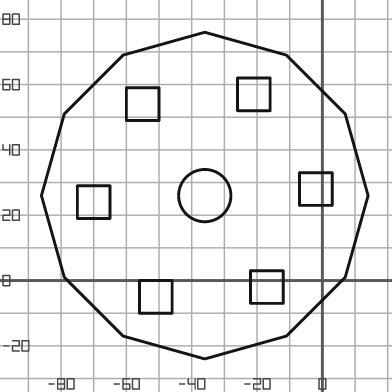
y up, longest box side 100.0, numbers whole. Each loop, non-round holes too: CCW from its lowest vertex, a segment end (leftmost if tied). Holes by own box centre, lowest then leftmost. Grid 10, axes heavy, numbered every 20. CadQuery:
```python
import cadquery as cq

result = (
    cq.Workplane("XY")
    .moveTo(-36.0, -24.0)
    .lineTo(-11.0, -17.0)
    .lineTo(7.0, 1.0)
    .lineTo(14.0, 26.0)
    .lineTo(7.0, 51.0)
    .lineTo(-11.0, 69.0)
    .lineTo(-36.0, 76.0)
    .lineTo(-61.0, 69.0)
    .lineTo(-79.0, 51.0)
    .lineTo(-86.0, 26.0)
    .lineTo(-79.0, 1.0)
    .lineTo(-61.0, -17.0)
    .close()
    .moveTo(-56.0, -10.0)
    .lineTo(-46.0, -10.0)
    .lineTo(-46.0, 0.0)
    .lineTo(-56.0, 0.0)
    .close()
    .moveTo(-22.0, -7.0)
    .lineTo(-12.0, -7.0)
    .lineTo(-12.0, 3.0)
    .lineTo(-22.0, 3.0)
    .close()
    .moveTo(-75.0, 19.0)
    .lineTo(-65.0, 19.0)
    .lineTo(-65.0, 29.0)
    .lineTo(-75.0, 29.0)
    .close()
    .moveTo(-36.0, 26.0)
    .circle(8.0)
    .moveTo(-7.0, 23.0)
    .lineTo(3.0, 23.0)
    .lineTo(3.0, 33.0)
    .lineTo(-7.0, 33.0)
    .close()
    .moveTo(-60.0, 49.0)
    .lineTo(-50.0, 49.0)
    .lineTo(-50.0, 59.0)
    .lineTo(-60.0, 59.0)
    .close()
    .moveTo(-26.0, 52.0)
    .lineTo(-16.0, 52.0)
    .lineTo(-16.0, 62.0)
    .lineTo(-26.0, 62.0)
    .close()
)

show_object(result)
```